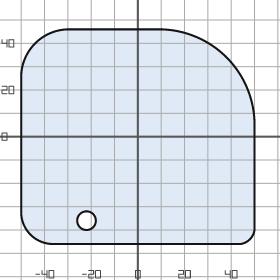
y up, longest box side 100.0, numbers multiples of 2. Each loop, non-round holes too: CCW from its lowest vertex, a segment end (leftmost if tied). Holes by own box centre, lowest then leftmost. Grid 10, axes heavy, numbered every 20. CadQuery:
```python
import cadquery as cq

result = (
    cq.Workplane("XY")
    .moveTo(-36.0, -46.0)
    .lineTo(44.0, -46.0)
    .threePointArc((48.0, -44.0), (50.0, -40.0))
    .lineTo(50.0, 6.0)
    .threePointArc((38.0, 34.0), (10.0, 46.0))
    .lineTo(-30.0, 46.0)
    .threePointArc((-44.0, 40.0), (-50.0, 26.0))
    .lineTo(-50.0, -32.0)
    .threePointArc((-46.0, -42.0), (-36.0, -46.0))
    .close()
    .moveTo(-22.0, -36.0)
    .circle(4.0)
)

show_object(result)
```